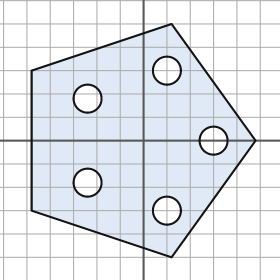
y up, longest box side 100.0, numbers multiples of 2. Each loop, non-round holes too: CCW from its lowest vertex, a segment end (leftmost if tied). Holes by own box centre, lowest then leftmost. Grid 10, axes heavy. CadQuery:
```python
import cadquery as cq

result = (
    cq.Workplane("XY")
    .moveTo(12.0, -50.0)
    .lineTo(48.0, 0.0)
    .lineTo(12.0, 50.0)
    .lineTo(-48.0, 30.0)
    .lineTo(-48.0, -30.0)
    .close()
    .moveTo(10.0, -30.0)
    .circle(6.0)
    .moveTo(-24.0, -18.0)
    .circle(6.0)
    .moveTo(30.0, 0.0)
    .circle(6.0)
    .moveTo(-24.0, 18.0)
    .circle(6.0)
    .moveTo(10.0, 30.0)
    .circle(6.0)
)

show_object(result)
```